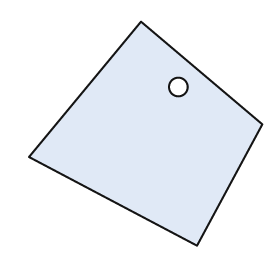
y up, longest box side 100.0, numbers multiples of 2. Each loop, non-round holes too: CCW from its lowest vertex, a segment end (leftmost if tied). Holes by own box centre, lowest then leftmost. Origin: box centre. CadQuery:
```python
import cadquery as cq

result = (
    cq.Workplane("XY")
    .moveTo(22.0, -48.0)
    .lineTo(50.0, 4.0)
    .lineTo(-2.0, 48.0)
    .lineTo(-50.0, -10.0)
    .close()
    .moveTo(14.0, 20.0)
    .circle(4.0)
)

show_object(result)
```